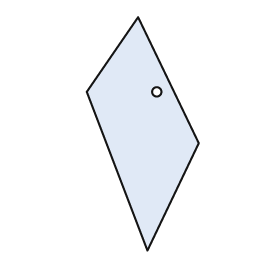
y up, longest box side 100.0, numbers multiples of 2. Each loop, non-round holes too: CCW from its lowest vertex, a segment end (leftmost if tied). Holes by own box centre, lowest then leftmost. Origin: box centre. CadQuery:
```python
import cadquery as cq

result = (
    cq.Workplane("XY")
    .moveTo(2.0, -50.0)
    .lineTo(24.0, -4.0)
    .lineTo(-2.0, 50.0)
    .lineTo(-24.0, 18.0)
    .close()
    .moveTo(6.0, 18.0)
    .circle(2.0)
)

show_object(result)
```